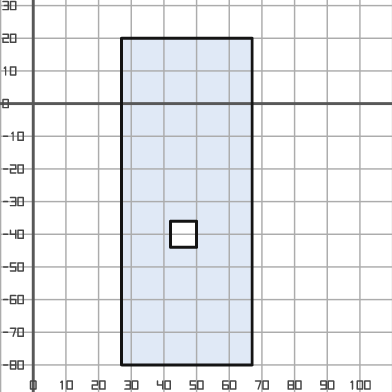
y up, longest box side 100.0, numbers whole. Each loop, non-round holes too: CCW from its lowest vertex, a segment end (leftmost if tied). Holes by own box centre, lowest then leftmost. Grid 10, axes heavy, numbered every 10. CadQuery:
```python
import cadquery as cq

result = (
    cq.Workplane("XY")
    .moveTo(27.0, -80.0)
    .lineTo(67.0, -80.0)
    .lineTo(67.0, 20.0)
    .lineTo(27.0, 20.0)
    .close()
    .moveTo(42.0, -44.0)
    .lineTo(50.0, -44.0)
    .lineTo(50.0, -36.0)
    .lineTo(42.0, -36.0)
    .close()
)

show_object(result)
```